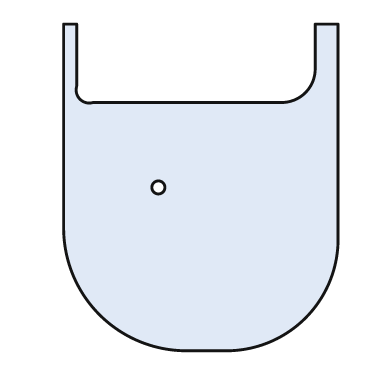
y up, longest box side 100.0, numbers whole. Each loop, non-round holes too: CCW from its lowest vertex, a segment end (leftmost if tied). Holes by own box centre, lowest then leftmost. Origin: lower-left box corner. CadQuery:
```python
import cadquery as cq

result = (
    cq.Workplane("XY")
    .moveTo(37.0, 0.0)
    .lineTo(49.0, 0.0)
    .threePointArc((74.0, 10.0), (84.0, 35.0))
    .lineTo(84.0, 100.0)
    .lineTo(77.0, 100.0)
    .lineTo(77.0, 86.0)
    .threePointArc((74.0, 79.0), (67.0, 76.0))
    .lineTo(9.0, 76.0)
    .threePointArc((5.0, 77.0), (4.0, 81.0))
    .lineTo(4.0, 100.0)
    .lineTo(0.0, 100.0)
    .lineTo(0.0, 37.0)
    .threePointArc((11.0, 11.0), (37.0, 0.0))
    .close()
    .moveTo(29.0, 50.0)
    .circle(2.0)
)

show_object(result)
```